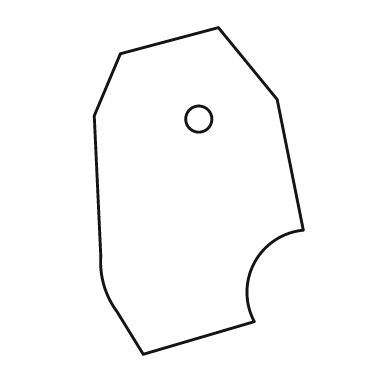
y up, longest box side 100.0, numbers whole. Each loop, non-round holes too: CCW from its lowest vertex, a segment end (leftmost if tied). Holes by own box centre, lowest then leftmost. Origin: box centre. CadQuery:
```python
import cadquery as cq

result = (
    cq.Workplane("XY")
    .moveTo(-17.0, -50.0)
    .lineTo(17.0, -40.0)
    .threePointArc((17.0, -22.0), (32.0, -12.0))
    .lineTo(24.0, 28.0)
    .lineTo(6.0, 50.0)
    .lineTo(-24.0, 42.0)
    .lineTo(-32.0, 23.0)
    .lineTo(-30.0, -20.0)
    .threePointArc((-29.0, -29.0), (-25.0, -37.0))
    .close()
    .moveTo(0.0, 22.0)
    .circle(4.0)
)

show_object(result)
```